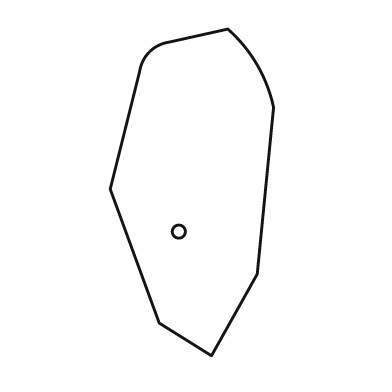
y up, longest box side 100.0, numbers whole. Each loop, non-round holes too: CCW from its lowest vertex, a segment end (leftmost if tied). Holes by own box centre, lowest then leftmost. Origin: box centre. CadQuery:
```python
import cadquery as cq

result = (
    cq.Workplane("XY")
    .moveTo(6.0, -50.0)
    .lineTo(20.0, -25.0)
    .lineTo(25.0, 26.0)
    .threePointArc((20.0, 39.0), (11.0, 50.0))
    .lineTo(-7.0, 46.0)
    .threePointArc((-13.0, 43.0), (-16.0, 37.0))
    .lineTo(-25.0, 1.0)
    .lineTo(-10.0, -40.0)
    .close()
    .moveTo(-4.0, -12.0)
    .circle(2.0)
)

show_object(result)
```